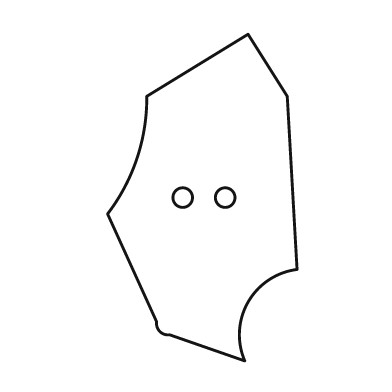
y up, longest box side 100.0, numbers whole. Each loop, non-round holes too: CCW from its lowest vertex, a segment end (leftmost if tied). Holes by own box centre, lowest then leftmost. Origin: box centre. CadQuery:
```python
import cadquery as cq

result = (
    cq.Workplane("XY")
    .moveTo(13.0, -50.0)
    .threePointArc((14.0, -32.0), (29.0, -22.0))
    .lineTo(26.0, 31.0)
    .lineTo(14.0, 50.0)
    .lineTo(-17.0, 31.0)
    .threePointArc((-20.0, 12.0), (-29.0, -5.0))
    .lineTo(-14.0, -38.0)
    .threePointArc((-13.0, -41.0), (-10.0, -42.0))
    .close()
    .moveTo(-6.0, 0.0)
    .circle(3.0)
    .moveTo(7.0, 0.0)
    .circle(3.0)
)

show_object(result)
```